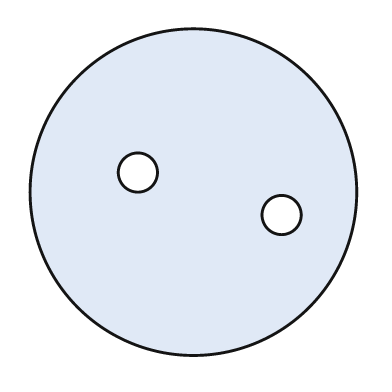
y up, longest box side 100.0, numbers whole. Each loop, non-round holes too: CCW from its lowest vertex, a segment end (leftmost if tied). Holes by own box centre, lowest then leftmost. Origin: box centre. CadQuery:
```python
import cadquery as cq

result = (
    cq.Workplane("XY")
    .moveTo(0.0, 0.0)
    .circle(50.0)
    .moveTo(27.0, -7.0)
    .circle(6.0)
    .moveTo(-17.0, 6.0)
    .circle(6.0)
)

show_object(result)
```